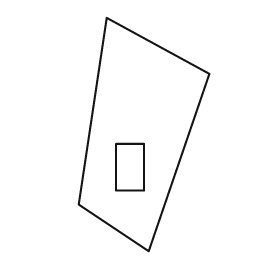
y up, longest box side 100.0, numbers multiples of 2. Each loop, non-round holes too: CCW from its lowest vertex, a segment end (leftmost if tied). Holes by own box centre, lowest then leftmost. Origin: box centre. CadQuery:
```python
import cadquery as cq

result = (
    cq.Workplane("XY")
    .moveTo(2.0, -50.0)
    .lineTo(28.0, 26.0)
    .lineTo(-16.0, 50.0)
    .lineTo(-28.0, -30.0)
    .close()
    .moveTo(-12.0, -24.0)
    .lineTo(0.0, -24.0)
    .lineTo(0.0, -4.0)
    .lineTo(-12.0, -4.0)
    .close()
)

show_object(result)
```